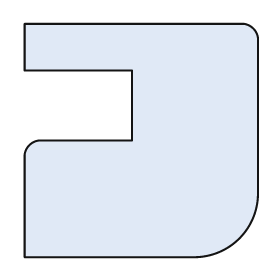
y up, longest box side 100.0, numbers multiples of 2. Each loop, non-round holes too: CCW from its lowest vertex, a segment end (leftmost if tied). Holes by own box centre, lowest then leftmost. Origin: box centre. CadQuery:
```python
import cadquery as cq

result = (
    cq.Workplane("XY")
    .moveTo(-50.0, -50.0)
    .lineTo(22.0, -50.0)
    .threePointArc((42.0, -42.0), (50.0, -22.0))
    .lineTo(50.0, 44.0)
    .threePointArc((48.0, 48.0), (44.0, 50.0))
    .lineTo(-50.0, 50.0)
    .lineTo(-50.0, 30.0)
    .lineTo(-4.0, 30.0)
    .lineTo(-4.0, 0.0)
    .lineTo(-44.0, 0.0)
    .threePointArc((-48.0, -2.0), (-50.0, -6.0))
    .close()
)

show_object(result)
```